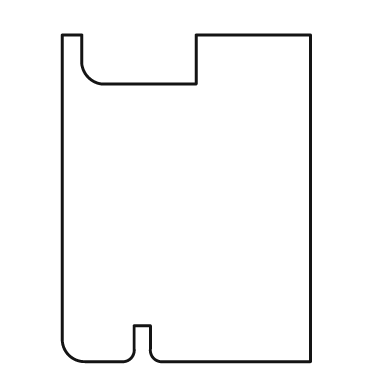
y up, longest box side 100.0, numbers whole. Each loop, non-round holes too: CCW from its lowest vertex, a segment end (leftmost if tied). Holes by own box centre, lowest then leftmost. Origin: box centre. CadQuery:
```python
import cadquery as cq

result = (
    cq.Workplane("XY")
    .moveTo(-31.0, -50.0)
    .lineTo(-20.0, -50.0)
    .threePointArc((-17.0, -49.0), (-16.0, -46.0))
    .lineTo(-16.0, -39.0)
    .lineTo(-11.0, -39.0)
    .lineTo(-11.0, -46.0)
    .threePointArc((-10.0, -49.0), (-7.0, -50.0))
    .lineTo(38.0, -50.0)
    .lineTo(38.0, 50.0)
    .lineTo(3.0, 50.0)
    .lineTo(3.0, 35.0)
    .lineTo(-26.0, 35.0)
    .threePointArc((-30.0, 37.0), (-32.0, 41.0))
    .lineTo(-32.0, 50.0)
    .lineTo(-38.0, 50.0)
    .lineTo(-38.0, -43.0)
    .threePointArc((-36.0, -48.0), (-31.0, -50.0))
    .close()
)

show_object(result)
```